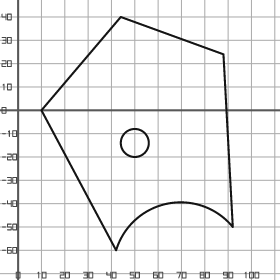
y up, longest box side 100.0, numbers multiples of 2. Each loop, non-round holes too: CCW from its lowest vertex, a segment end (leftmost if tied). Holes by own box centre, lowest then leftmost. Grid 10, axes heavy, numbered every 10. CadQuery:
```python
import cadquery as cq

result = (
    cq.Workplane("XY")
    .moveTo(42.0, -60.0)
    .threePointArc((64.0, -40.0), (92.0, -50.0))
    .lineTo(88.0, 24.0)
    .lineTo(44.0, 40.0)
    .lineTo(10.0, 0.0)
    .close()
    .moveTo(50.0, -14.0)
    .circle(6.0)
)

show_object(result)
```